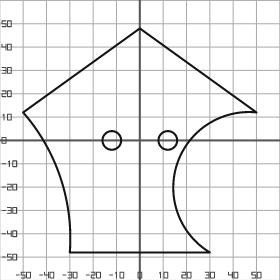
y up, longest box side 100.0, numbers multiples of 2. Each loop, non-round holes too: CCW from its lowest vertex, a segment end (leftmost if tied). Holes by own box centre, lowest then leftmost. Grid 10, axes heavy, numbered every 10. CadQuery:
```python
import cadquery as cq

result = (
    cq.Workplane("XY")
    .moveTo(-30.0, -48.0)
    .lineTo(30.0, -48.0)
    .threePointArc((16.0, -10.0), (50.0, 12.0))
    .lineTo(0.0, 48.0)
    .lineTo(-50.0, 12.0)
    .threePointArc((-34.0, -16.0), (-30.0, -48.0))
    .close()
    .moveTo(-12.0, 0.0)
    .circle(4.0)
    .moveTo(12.0, 0.0)
    .circle(4.0)
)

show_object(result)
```